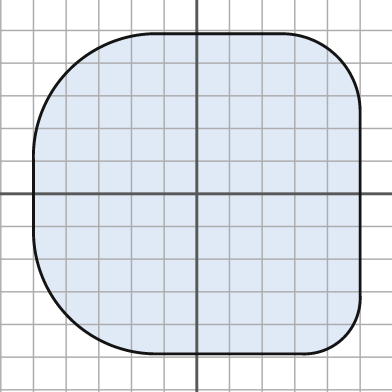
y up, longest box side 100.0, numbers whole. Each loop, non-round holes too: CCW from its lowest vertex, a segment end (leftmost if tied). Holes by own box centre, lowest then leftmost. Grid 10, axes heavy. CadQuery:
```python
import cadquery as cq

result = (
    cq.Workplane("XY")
    .moveTo(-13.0, -49.0)
    .lineTo(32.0, -49.0)
    .threePointArc((45.0, -44.0), (50.0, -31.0))
    .lineTo(50.0, 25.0)
    .threePointArc((43.0, 42.0), (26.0, 49.0))
    .lineTo(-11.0, 49.0)
    .threePointArc((-39.0, 38.0), (-50.0, 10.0))
    .lineTo(-50.0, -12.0)
    .threePointArc((-39.0, -38.0), (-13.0, -49.0))
    .close()
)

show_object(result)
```